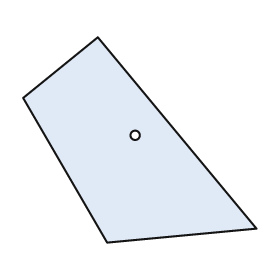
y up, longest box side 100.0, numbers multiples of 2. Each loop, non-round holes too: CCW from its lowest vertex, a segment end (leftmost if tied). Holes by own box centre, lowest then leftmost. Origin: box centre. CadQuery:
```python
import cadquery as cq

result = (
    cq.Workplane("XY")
    .moveTo(-14.0, -44.0)
    .lineTo(50.0, -38.0)
    .lineTo(-18.0, 44.0)
    .lineTo(-50.0, 18.0)
    .close()
    .moveTo(-2.0, 2.0)
    .circle(2.0)
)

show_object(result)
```